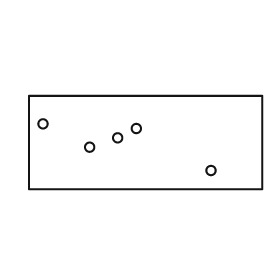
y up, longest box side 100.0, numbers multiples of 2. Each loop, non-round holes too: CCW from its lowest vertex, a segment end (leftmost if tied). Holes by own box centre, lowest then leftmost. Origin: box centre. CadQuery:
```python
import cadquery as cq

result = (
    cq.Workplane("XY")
    .moveTo(-50.0, -20.0)
    .lineTo(50.0, -20.0)
    .lineTo(50.0, 20.0)
    .lineTo(-50.0, 20.0)
    .close()
    .moveTo(28.0, -12.0)
    .circle(2.0)
    .moveTo(-24.0, -2.0)
    .circle(2.0)
    .moveTo(-12.0, 2.0)
    .circle(2.0)
    .moveTo(-4.0, 6.0)
    .circle(2.0)
    .moveTo(-44.0, 8.0)
    .circle(2.0)
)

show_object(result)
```